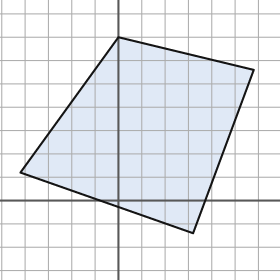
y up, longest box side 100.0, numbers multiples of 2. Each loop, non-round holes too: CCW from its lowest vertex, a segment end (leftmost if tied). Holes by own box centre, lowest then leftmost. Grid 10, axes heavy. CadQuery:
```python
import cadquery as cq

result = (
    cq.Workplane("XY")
    .moveTo(32.0, -14.0)
    .lineTo(58.0, 56.0)
    .lineTo(0.0, 70.0)
    .lineTo(-42.0, 12.0)
    .close()
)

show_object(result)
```